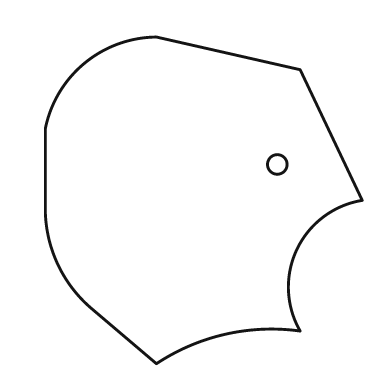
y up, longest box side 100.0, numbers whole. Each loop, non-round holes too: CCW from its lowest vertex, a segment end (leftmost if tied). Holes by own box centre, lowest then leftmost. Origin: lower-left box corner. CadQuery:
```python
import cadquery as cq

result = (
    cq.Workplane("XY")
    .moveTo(34.0, 0.0)
    .threePointArc((55.0, 9.0), (78.0, 10.0))
    .threePointArc((77.0, 35.0), (97.0, 50.0))
    .lineTo(78.0, 90.0)
    .lineTo(34.0, 100.0)
    .threePointArc((12.0, 92.0), (0.0, 72.0))
    .lineTo(0.0, 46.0)
    .threePointArc((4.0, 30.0), (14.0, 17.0))
    .close()
    .moveTo(71.0, 61.0)
    .circle(3.0)
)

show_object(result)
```